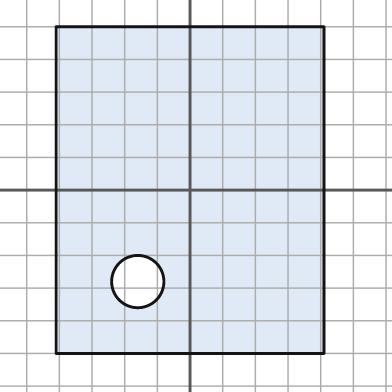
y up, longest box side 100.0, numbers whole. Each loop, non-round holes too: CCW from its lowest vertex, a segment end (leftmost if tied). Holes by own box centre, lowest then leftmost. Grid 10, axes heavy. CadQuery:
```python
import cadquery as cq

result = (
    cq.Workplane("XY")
    .moveTo(-41.0, -50.0)
    .lineTo(41.0, -50.0)
    .lineTo(41.0, 50.0)
    .lineTo(-41.0, 50.0)
    .close()
    .moveTo(-16.0, -28.0)
    .circle(8.0)
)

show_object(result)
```